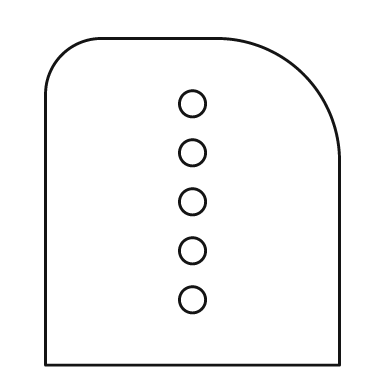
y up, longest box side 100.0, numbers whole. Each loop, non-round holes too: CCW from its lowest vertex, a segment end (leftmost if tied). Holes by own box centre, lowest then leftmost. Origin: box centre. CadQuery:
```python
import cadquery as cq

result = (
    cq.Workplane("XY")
    .moveTo(-45.0, -50.0)
    .lineTo(45.0, -50.0)
    .lineTo(45.0, 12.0)
    .threePointArc((34.0, 39.0), (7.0, 50.0))
    .lineTo(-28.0, 50.0)
    .threePointArc((-40.0, 45.0), (-45.0, 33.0))
    .close()
    .moveTo(0.0, -30.0)
    .circle(4.0)
    .moveTo(0.0, -15.0)
    .circle(4.0)
    .moveTo(0.0, 0.0)
    .circle(4.0)
    .moveTo(0.0, 15.0)
    .circle(4.0)
    .moveTo(0.0, 30.0)
    .circle(4.0)
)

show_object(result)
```